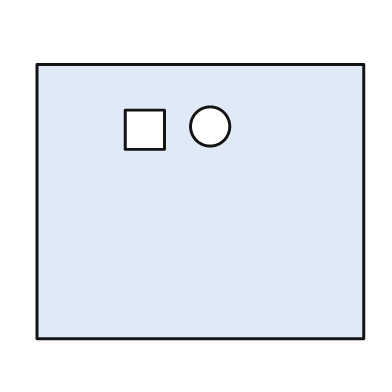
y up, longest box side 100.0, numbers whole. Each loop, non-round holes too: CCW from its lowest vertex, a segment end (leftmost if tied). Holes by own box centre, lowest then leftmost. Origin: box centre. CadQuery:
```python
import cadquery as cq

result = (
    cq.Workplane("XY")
    .moveTo(-50.0, -42.0)
    .lineTo(50.0, -42.0)
    .lineTo(50.0, 42.0)
    .lineTo(-50.0, 42.0)
    .close()
    .moveTo(-23.0, 16.0)
    .lineTo(-11.0, 16.0)
    .lineTo(-11.0, 28.0)
    .lineTo(-23.0, 28.0)
    .close()
    .moveTo(3.0, 23.0)
    .circle(6.0)
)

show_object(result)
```